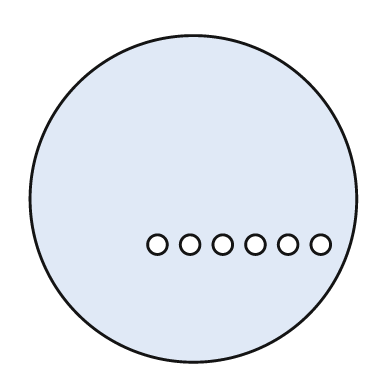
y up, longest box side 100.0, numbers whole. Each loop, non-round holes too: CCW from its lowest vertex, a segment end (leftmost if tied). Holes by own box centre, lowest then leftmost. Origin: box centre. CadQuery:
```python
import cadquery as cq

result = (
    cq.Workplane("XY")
    .moveTo(0.0, 0.0)
    .circle(50.0)
    .moveTo(-11.0, -14.0)
    .circle(3.0)
    .moveTo(-1.0, -14.0)
    .circle(3.0)
    .moveTo(9.0, -14.0)
    .circle(3.0)
    .moveTo(19.0, -14.0)
    .circle(3.0)
    .moveTo(29.0, -14.0)
    .circle(3.0)
    .moveTo(39.0, -14.0)
    .circle(3.0)
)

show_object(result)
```